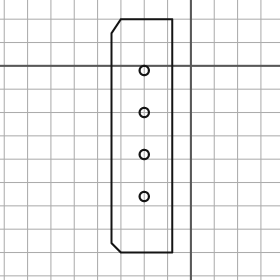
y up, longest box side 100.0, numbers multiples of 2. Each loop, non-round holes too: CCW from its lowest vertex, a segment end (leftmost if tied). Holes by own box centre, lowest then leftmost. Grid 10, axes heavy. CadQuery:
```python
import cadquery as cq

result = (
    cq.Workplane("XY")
    .moveTo(-30.0, -80.0)
    .lineTo(-8.0, -80.0)
    .lineTo(-8.0, 20.0)
    .lineTo(-30.0, 20.0)
    .lineTo(-34.0, 14.0)
    .lineTo(-34.0, -76.0)
    .close()
    .moveTo(-20.0, -56.0)
    .circle(2.0)
    .moveTo(-20.0, -38.0)
    .circle(2.0)
    .moveTo(-20.0, -20.0)
    .circle(2.0)
    .moveTo(-20.0, -2.0)
    .circle(2.0)
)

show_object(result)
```